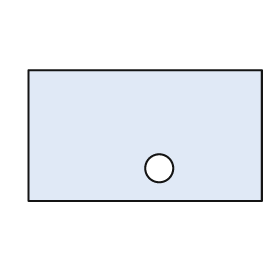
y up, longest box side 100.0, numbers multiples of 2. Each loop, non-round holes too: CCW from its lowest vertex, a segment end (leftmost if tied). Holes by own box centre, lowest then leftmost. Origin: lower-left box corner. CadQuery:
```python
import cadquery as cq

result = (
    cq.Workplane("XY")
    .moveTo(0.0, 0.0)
    .lineTo(100.0, 0.0)
    .lineTo(100.0, 56.0)
    .lineTo(0.0, 56.0)
    .close()
    .moveTo(56.0, 14.0)
    .circle(6.0)
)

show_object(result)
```